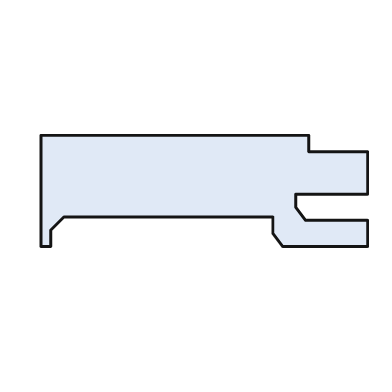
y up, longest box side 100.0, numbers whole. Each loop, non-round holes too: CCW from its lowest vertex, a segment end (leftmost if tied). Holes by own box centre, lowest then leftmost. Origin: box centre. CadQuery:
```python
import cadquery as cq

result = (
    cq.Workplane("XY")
    .moveTo(-50.0, -17.0)
    .lineTo(-47.0, -17.0)
    .lineTo(-47.0, -12.0)
    .lineTo(-43.0, -8.0)
    .lineTo(21.0, -8.0)
    .lineTo(21.0, -13.0)
    .lineTo(24.0, -17.0)
    .lineTo(50.0, -17.0)
    .lineTo(50.0, -9.0)
    .lineTo(31.0, -9.0)
    .lineTo(28.0, -5.0)
    .lineTo(28.0, -1.0)
    .lineTo(50.0, -1.0)
    .lineTo(50.0, 12.0)
    .lineTo(32.0, 12.0)
    .lineTo(32.0, 17.0)
    .lineTo(-50.0, 17.0)
    .close()
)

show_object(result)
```